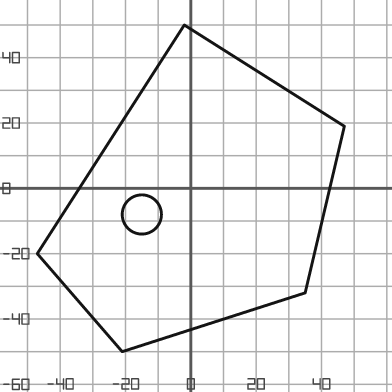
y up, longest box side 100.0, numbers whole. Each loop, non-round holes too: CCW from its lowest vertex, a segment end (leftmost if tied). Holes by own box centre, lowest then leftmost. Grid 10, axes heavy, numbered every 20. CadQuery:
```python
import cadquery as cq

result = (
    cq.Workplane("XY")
    .moveTo(-21.0, -50.0)
    .lineTo(35.0, -32.0)
    .lineTo(47.0, 19.0)
    .lineTo(-2.0, 50.0)
    .lineTo(-47.0, -20.0)
    .close()
    .moveTo(-15.0, -8.0)
    .circle(6.0)
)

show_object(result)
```